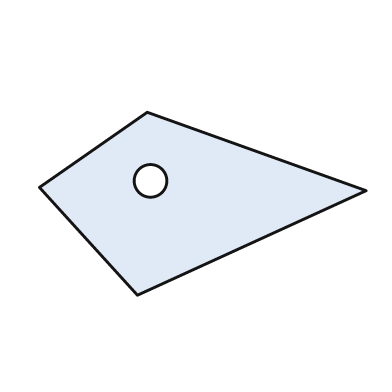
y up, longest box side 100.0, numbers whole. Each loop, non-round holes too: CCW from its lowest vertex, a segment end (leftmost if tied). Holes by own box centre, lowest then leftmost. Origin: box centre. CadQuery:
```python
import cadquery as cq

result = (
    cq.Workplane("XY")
    .moveTo(-20.0, -28.0)
    .lineTo(50.0, 4.0)
    .lineTo(-17.0, 28.0)
    .lineTo(-50.0, 5.0)
    .close()
    .moveTo(-16.0, 7.0)
    .circle(5.0)
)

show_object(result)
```